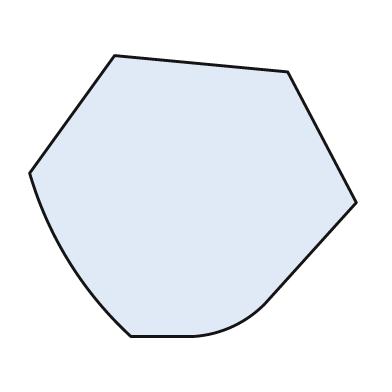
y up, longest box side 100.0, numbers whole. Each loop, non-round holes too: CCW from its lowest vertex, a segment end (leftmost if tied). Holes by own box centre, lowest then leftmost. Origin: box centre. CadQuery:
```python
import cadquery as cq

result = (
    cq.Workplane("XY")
    .moveTo(-19.0, -43.0)
    .lineTo(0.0, -43.0)
    .threePointArc((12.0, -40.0), (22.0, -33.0))
    .lineTo(50.0, -2.0)
    .lineTo(29.0, 38.0)
    .lineTo(-24.0, 43.0)
    .lineTo(-50.0, 7.0)
    .threePointArc((-38.0, -20.0), (-19.0, -43.0))
    .close()
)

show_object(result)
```